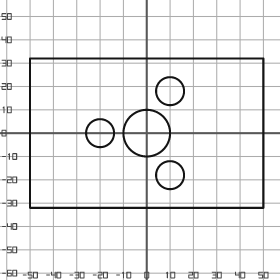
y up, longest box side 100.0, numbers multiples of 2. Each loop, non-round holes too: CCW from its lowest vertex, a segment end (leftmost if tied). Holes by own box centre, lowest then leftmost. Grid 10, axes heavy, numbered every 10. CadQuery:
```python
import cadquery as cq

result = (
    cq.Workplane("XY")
    .moveTo(-50.0, -32.0)
    .lineTo(50.0, -32.0)
    .lineTo(50.0, 32.0)
    .lineTo(-50.0, 32.0)
    .close()
    .moveTo(10.0, -18.0)
    .circle(6.0)
    .moveTo(-20.0, 0.0)
    .circle(6.0)
    .moveTo(0.0, 0.0)
    .circle(10.0)
    .moveTo(10.0, 18.0)
    .circle(6.0)
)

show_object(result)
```